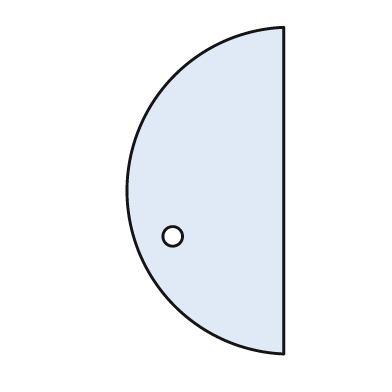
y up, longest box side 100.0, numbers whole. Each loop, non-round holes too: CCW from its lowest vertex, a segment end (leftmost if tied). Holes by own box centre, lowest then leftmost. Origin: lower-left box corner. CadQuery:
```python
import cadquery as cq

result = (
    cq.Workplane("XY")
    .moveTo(48.0, 0.0)
    .lineTo(48.0, 100.0)
    .threePointArc((0.0, 50.0), (48.0, 0.0))
    .close()
    .moveTo(14.0, 36.0)
    .circle(3.0)
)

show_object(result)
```